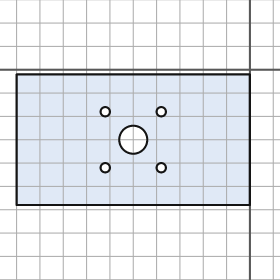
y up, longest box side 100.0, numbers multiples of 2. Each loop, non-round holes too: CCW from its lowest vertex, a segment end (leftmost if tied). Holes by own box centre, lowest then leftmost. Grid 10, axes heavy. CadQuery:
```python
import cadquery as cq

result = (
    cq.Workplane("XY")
    .moveTo(-100.0, -58.0)
    .lineTo(0.0, -58.0)
    .lineTo(0.0, -2.0)
    .lineTo(-100.0, -2.0)
    .close()
    .moveTo(-62.0, -42.0)
    .circle(2.0)
    .moveTo(-38.0, -42.0)
    .circle(2.0)
    .moveTo(-50.0, -30.0)
    .circle(6.0)
    .moveTo(-62.0, -18.0)
    .circle(2.0)
    .moveTo(-38.0, -18.0)
    .circle(2.0)
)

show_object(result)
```